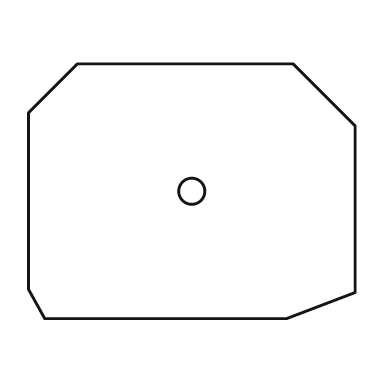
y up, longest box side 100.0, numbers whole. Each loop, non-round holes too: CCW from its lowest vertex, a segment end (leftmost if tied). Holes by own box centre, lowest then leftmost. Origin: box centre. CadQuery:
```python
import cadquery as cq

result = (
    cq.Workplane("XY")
    .moveTo(-45.0, -39.0)
    .lineTo(29.0, -39.0)
    .lineTo(50.0, -31.0)
    .lineTo(50.0, 20.0)
    .lineTo(31.0, 39.0)
    .lineTo(-35.0, 39.0)
    .lineTo(-50.0, 24.0)
    .lineTo(-50.0, -30.0)
    .close()
    .moveTo(0.0, 0.0)
    .circle(4.0)
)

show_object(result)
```